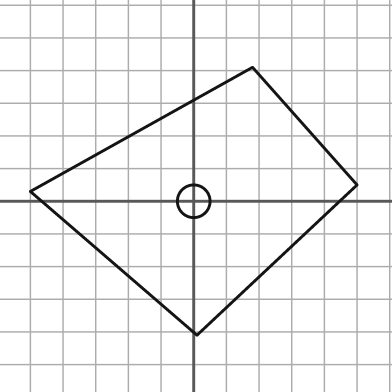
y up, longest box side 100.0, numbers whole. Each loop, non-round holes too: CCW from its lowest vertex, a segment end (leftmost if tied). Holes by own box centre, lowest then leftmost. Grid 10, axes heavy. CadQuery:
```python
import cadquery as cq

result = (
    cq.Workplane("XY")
    .moveTo(1.0, -41.0)
    .lineTo(50.0, 5.0)
    .lineTo(18.0, 41.0)
    .lineTo(-50.0, 3.0)
    .close()
    .moveTo(0.0, 0.0)
    .circle(5.0)
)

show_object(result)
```